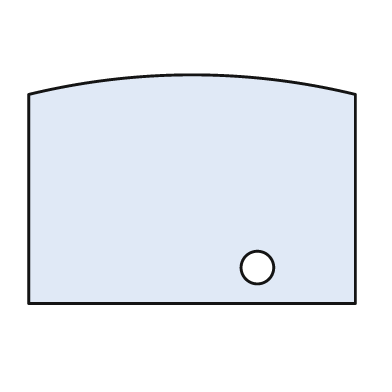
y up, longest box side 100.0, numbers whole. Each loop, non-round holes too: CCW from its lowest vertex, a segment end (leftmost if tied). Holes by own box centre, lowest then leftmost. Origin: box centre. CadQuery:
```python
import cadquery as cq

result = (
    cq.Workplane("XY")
    .moveTo(-50.0, -35.0)
    .lineTo(50.0, -35.0)
    .lineTo(50.0, 29.0)
    .threePointArc((0.0, 35.0), (-50.0, 29.0))
    .close()
    .moveTo(20.0, -24.0)
    .circle(5.0)
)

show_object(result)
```